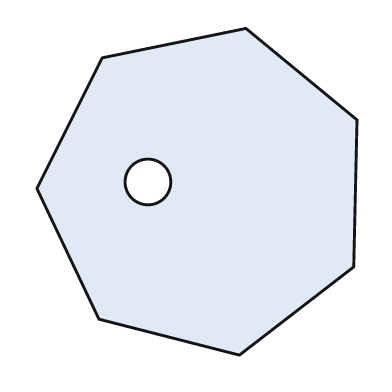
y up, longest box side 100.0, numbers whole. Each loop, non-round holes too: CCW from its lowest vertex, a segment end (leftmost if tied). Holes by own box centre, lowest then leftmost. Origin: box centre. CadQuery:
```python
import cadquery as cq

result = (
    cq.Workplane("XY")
    .moveTo(13.0, -50.0)
    .lineTo(48.0, -23.0)
    .lineTo(49.0, 22.0)
    .lineTo(15.0, 50.0)
    .lineTo(-29.0, 41.0)
    .lineTo(-49.0, 1.0)
    .lineTo(-30.0, -39.0)
    .close()
    .moveTo(-15.0, 3.0)
    .circle(7.0)
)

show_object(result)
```